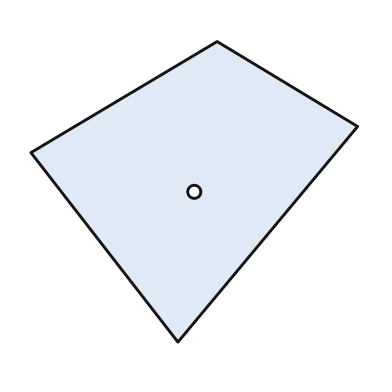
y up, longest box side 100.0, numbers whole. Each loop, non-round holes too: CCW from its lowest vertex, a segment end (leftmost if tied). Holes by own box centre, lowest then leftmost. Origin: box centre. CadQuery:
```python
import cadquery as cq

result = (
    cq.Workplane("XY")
    .moveTo(-5.0, -46.0)
    .lineTo(50.0, 20.0)
    .lineTo(7.0, 46.0)
    .lineTo(-50.0, 12.0)
    .close()
    .moveTo(0.0, 0.0)
    .circle(2.0)
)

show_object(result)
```